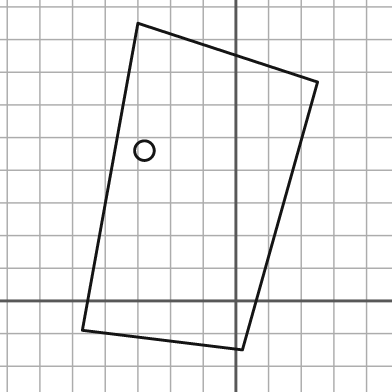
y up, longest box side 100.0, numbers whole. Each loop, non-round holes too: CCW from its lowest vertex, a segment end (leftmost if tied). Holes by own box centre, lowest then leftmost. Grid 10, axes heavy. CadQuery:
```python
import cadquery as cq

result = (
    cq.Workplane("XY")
    .moveTo(2.0, -15.0)
    .lineTo(25.0, 67.0)
    .lineTo(-30.0, 85.0)
    .lineTo(-47.0, -9.0)
    .close()
    .moveTo(-28.0, 46.0)
    .circle(3.0)
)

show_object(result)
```